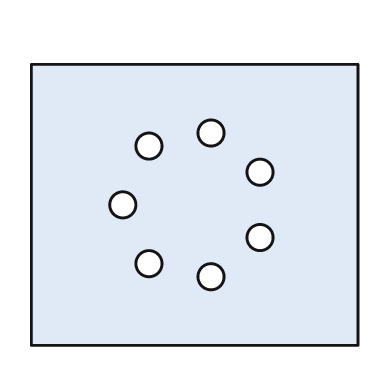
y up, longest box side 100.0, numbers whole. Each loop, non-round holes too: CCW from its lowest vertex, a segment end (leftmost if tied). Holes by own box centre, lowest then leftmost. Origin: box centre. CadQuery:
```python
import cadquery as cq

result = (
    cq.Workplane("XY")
    .moveTo(-50.0, -43.0)
    .lineTo(50.0, -43.0)
    .lineTo(50.0, 43.0)
    .lineTo(-50.0, 43.0)
    .close()
    .moveTo(5.0, -22.0)
    .circle(4.0)
    .moveTo(-14.0, -18.0)
    .circle(4.0)
    .moveTo(20.0, -10.0)
    .circle(4.0)
    .moveTo(-22.0, 0.0)
    .circle(4.0)
    .moveTo(20.0, 10.0)
    .circle(4.0)
    .moveTo(-14.0, 18.0)
    .circle(4.0)
    .moveTo(5.0, 22.0)
    .circle(4.0)
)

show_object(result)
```